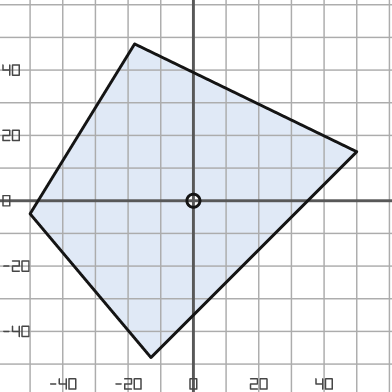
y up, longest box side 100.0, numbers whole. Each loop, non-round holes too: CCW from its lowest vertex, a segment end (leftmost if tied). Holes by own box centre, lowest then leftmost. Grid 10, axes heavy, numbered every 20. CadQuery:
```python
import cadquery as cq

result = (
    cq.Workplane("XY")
    .moveTo(-13.0, -48.0)
    .lineTo(50.0, 15.0)
    .lineTo(-18.0, 48.0)
    .lineTo(-50.0, -4.0)
    .close()
    .moveTo(0.0, 0.0)
    .circle(2.0)
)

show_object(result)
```